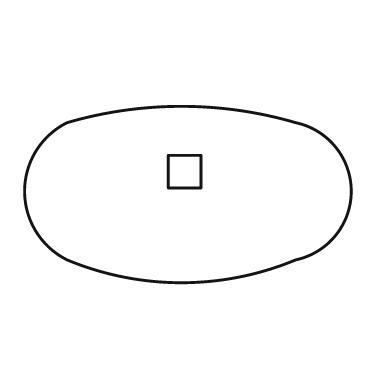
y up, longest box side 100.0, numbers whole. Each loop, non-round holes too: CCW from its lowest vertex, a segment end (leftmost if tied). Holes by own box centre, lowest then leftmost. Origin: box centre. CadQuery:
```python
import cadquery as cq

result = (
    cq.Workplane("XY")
    .moveTo(-37.0, -20.0)
    .threePointArc((-2.0, -27.0), (33.0, -20.0))
    .threePointArc((50.0, 1.0), (33.0, 22.0))
    .threePointArc((-2.0, 27.0), (-37.0, 22.0))
    .threePointArc((-50.0, 1.0), (-37.0, -20.0))
    .close()
    .moveTo(-6.0, 2.0)
    .lineTo(4.0, 2.0)
    .lineTo(4.0, 12.0)
    .lineTo(-6.0, 12.0)
    .close()
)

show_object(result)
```